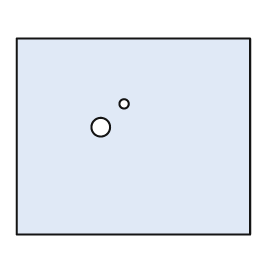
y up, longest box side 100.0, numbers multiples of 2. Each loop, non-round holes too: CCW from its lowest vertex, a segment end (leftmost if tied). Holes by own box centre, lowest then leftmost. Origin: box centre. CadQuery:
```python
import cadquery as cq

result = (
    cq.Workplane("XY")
    .moveTo(-50.0, -42.0)
    .lineTo(50.0, -42.0)
    .lineTo(50.0, 42.0)
    .lineTo(-50.0, 42.0)
    .close()
    .moveTo(-14.0, 4.0)
    .circle(4.0)
    .moveTo(-4.0, 14.0)
    .circle(2.0)
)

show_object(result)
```